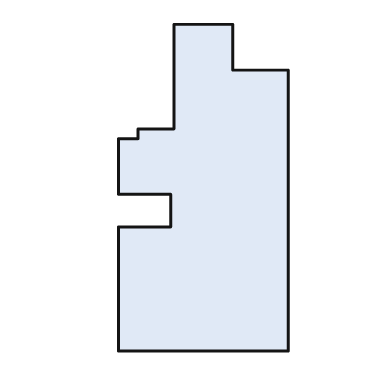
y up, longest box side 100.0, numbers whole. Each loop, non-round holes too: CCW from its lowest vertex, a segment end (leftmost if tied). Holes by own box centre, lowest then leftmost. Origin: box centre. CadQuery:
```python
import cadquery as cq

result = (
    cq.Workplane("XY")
    .moveTo(-26.0, -50.0)
    .lineTo(26.0, -50.0)
    .lineTo(26.0, 36.0)
    .lineTo(9.0, 36.0)
    .lineTo(9.0, 50.0)
    .lineTo(-9.0, 50.0)
    .lineTo(-9.0, 18.0)
    .lineTo(-20.0, 18.0)
    .lineTo(-20.0, 15.0)
    .lineTo(-26.0, 15.0)
    .lineTo(-26.0, -2.0)
    .lineTo(-10.0, -2.0)
    .lineTo(-10.0, -12.0)
    .lineTo(-26.0, -12.0)
    .close()
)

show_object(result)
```